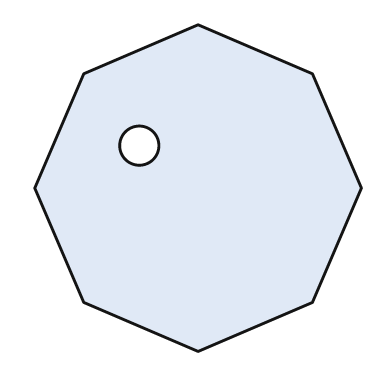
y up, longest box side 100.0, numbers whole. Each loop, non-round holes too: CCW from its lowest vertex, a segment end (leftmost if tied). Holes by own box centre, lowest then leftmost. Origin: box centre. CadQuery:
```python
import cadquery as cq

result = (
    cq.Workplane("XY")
    .moveTo(0.0, -50.0)
    .lineTo(35.0, -35.0)
    .lineTo(50.0, 0.0)
    .lineTo(35.0, 35.0)
    .lineTo(0.0, 50.0)
    .lineTo(-35.0, 35.0)
    .lineTo(-50.0, 0.0)
    .lineTo(-35.0, -35.0)
    .close()
    .moveTo(-18.0, 13.0)
    .circle(6.0)
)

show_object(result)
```